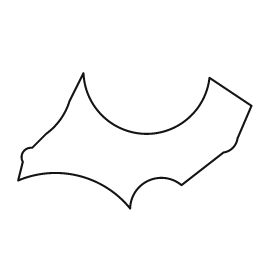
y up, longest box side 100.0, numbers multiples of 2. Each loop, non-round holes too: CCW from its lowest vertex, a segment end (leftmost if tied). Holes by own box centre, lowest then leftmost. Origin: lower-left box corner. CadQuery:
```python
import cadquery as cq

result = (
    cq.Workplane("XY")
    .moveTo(48.0, 0.0)
    .threePointArc((56.0, 12.0), (70.0, 10.0))
    .lineTo(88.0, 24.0)
    .threePointArc((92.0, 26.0), (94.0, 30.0))
    .lineTo(100.0, 44.0)
    .lineTo(82.0, 56.0)
    .threePointArc((54.0, 32.0), (28.0, 58.0))
    .lineTo(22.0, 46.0)
    .threePointArc((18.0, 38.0), (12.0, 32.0))
    .lineTo(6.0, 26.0)
    .threePointArc((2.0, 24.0), (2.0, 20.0))
    .lineTo(0.0, 12.0)
    .threePointArc((26.0, 14.0), (48.0, 0.0))
    .close()
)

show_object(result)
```